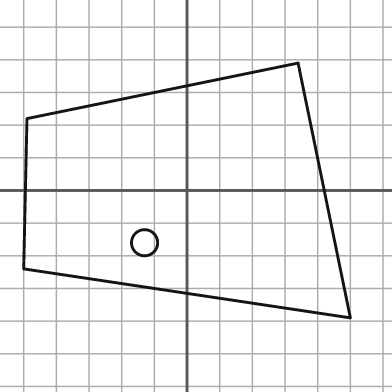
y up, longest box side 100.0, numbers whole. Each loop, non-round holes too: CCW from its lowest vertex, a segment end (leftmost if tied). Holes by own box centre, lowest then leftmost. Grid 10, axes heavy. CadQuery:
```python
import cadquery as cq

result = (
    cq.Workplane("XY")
    .moveTo(50.0, -39.0)
    .lineTo(34.0, 39.0)
    .lineTo(-49.0, 22.0)
    .lineTo(-50.0, -24.0)
    .close()
    .moveTo(-13.0, -16.0)
    .circle(4.0)
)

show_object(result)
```